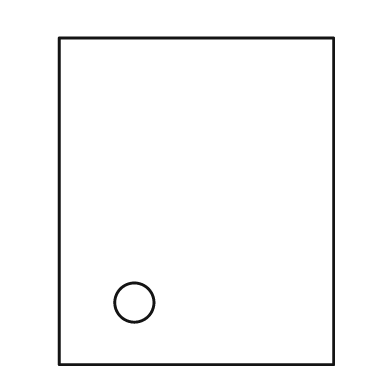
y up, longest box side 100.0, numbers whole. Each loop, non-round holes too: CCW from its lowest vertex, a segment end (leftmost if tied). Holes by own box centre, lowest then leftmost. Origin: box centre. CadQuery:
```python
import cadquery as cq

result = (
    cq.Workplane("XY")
    .moveTo(-42.0, -50.0)
    .lineTo(42.0, -50.0)
    .lineTo(42.0, 50.0)
    .lineTo(-42.0, 50.0)
    .close()
    .moveTo(-19.0, -31.0)
    .circle(6.0)
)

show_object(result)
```